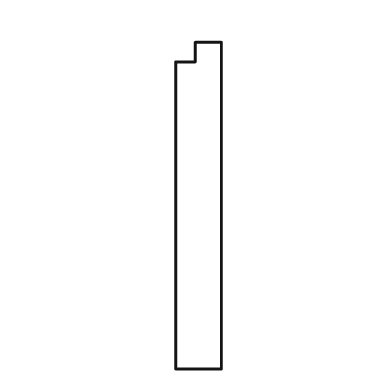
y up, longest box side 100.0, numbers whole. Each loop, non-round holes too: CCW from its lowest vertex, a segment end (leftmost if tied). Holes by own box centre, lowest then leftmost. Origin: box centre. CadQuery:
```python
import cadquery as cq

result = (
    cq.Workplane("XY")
    .moveTo(-7.0, -50.0)
    .lineTo(7.0, -50.0)
    .lineTo(7.0, 50.0)
    .lineTo(-1.0, 50.0)
    .lineTo(-1.0, 44.0)
    .lineTo(-7.0, 44.0)
    .close()
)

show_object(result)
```